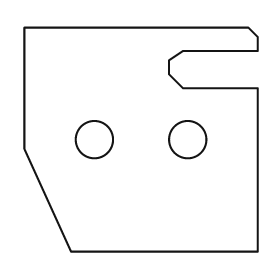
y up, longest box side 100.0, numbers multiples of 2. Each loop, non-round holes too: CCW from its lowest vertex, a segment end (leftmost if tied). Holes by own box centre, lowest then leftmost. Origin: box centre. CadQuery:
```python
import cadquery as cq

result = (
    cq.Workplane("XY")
    .moveTo(-30.0, -48.0)
    .lineTo(50.0, -48.0)
    .lineTo(50.0, 22.0)
    .lineTo(18.0, 22.0)
    .lineTo(12.0, 28.0)
    .lineTo(12.0, 34.0)
    .lineTo(18.0, 38.0)
    .lineTo(50.0, 38.0)
    .lineTo(50.0, 44.0)
    .lineTo(46.0, 48.0)
    .lineTo(-50.0, 48.0)
    .lineTo(-50.0, -4.0)
    .close()
    .moveTo(-20.0, 0.0)
    .circle(8.0)
    .moveTo(20.0, 0.0)
    .circle(8.0)
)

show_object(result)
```